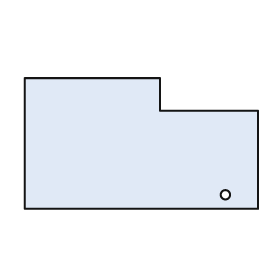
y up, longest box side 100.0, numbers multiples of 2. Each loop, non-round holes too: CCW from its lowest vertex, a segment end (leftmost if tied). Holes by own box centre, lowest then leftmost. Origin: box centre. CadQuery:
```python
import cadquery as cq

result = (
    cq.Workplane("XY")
    .moveTo(-50.0, -28.0)
    .lineTo(50.0, -28.0)
    .lineTo(50.0, 14.0)
    .lineTo(8.0, 14.0)
    .lineTo(8.0, 28.0)
    .lineTo(-50.0, 28.0)
    .close()
    .moveTo(36.0, -22.0)
    .circle(2.0)
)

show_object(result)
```